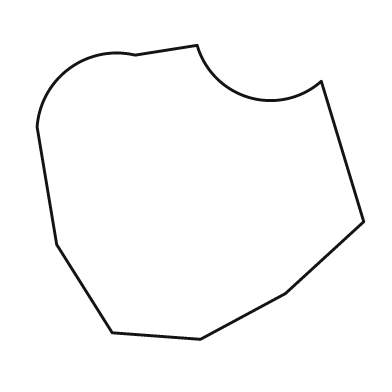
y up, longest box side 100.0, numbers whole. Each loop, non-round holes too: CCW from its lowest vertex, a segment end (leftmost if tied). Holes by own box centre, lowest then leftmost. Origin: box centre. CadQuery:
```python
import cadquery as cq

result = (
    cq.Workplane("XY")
    .moveTo(0.0, -45.0)
    .lineTo(26.0, -31.0)
    .lineTo(50.0, -9.0)
    .lineTo(37.0, 34.0)
    .threePointArc((15.0, 29.0), (-1.0, 45.0))
    .lineTo(-20.0, 42.0)
    .threePointArc((-40.0, 38.0), (-50.0, 20.0))
    .lineTo(-44.0, -16.0)
    .lineTo(-27.0, -43.0)
    .close()
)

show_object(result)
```